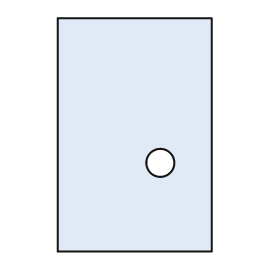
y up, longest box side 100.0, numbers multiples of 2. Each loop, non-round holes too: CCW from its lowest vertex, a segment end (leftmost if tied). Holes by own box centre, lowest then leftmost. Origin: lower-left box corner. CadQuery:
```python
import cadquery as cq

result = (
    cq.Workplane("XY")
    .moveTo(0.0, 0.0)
    .lineTo(66.0, 0.0)
    .lineTo(66.0, 100.0)
    .lineTo(0.0, 100.0)
    .close()
    .moveTo(44.0, 38.0)
    .circle(6.0)
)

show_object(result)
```